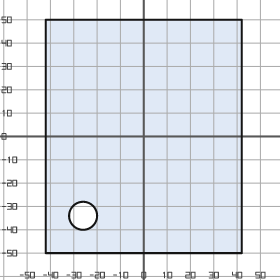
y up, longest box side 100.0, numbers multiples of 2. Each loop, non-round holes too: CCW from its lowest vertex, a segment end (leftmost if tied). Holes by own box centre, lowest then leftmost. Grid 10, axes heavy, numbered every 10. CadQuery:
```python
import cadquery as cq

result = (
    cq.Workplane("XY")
    .moveTo(-42.0, -50.0)
    .lineTo(42.0, -50.0)
    .lineTo(42.0, 50.0)
    .lineTo(-42.0, 50.0)
    .close()
    .moveTo(-26.0, -34.0)
    .circle(6.0)
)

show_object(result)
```